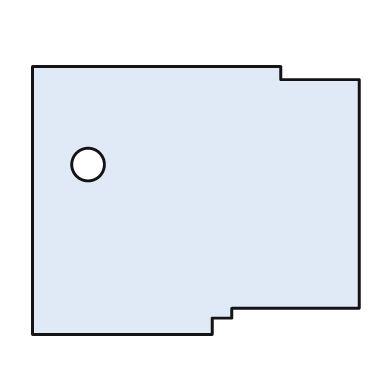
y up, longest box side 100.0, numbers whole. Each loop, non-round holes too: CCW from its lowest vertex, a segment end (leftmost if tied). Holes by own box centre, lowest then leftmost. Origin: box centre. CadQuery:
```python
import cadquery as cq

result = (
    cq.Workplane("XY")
    .moveTo(-50.0, -41.0)
    .lineTo(5.0, -41.0)
    .lineTo(5.0, -36.0)
    .lineTo(11.0, -36.0)
    .lineTo(11.0, -33.0)
    .lineTo(50.0, -33.0)
    .lineTo(50.0, 37.0)
    .lineTo(26.0, 37.0)
    .lineTo(26.0, 41.0)
    .lineTo(-50.0, 41.0)
    .close()
    .moveTo(-33.0, 11.0)
    .circle(5.0)
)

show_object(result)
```